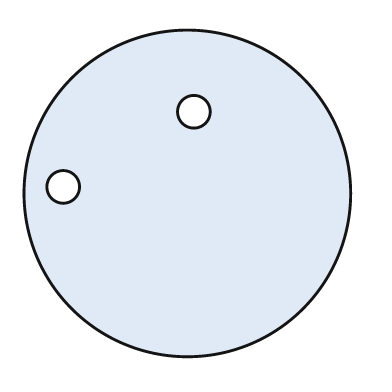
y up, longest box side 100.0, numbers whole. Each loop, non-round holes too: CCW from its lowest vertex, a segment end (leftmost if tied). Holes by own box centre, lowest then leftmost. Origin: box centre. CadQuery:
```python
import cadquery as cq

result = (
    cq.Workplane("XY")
    .moveTo(0.0, 0.0)
    .circle(50.0)
    .moveTo(-38.0, 2.0)
    .circle(5.0)
    .moveTo(2.0, 25.0)
    .circle(5.0)
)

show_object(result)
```